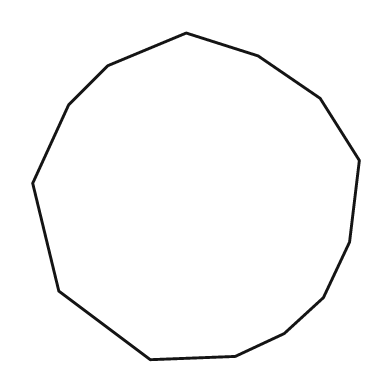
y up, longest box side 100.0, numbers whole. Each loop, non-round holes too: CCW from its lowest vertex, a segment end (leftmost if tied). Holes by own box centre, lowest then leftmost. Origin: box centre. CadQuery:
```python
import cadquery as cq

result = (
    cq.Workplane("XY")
    .moveTo(-14.0, -50.0)
    .lineTo(12.0, -49.0)
    .lineTo(27.0, -42.0)
    .lineTo(39.0, -31.0)
    .lineTo(47.0, -14.0)
    .lineTo(50.0, 11.0)
    .lineTo(38.0, 30.0)
    .lineTo(19.0, 43.0)
    .lineTo(-3.0, 50.0)
    .lineTo(-27.0, 40.0)
    .lineTo(-39.0, 28.0)
    .lineTo(-50.0, 4.0)
    .lineTo(-42.0, -29.0)
    .close()
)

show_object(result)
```